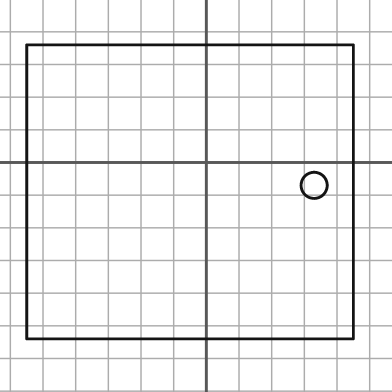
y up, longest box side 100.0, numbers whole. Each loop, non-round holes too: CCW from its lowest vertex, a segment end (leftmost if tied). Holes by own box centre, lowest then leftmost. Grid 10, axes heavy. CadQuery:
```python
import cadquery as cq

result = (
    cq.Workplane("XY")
    .moveTo(-55.0, -54.0)
    .lineTo(45.0, -54.0)
    .lineTo(45.0, 36.0)
    .lineTo(-55.0, 36.0)
    .close()
    .moveTo(33.0, -7.0)
    .circle(4.0)
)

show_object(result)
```